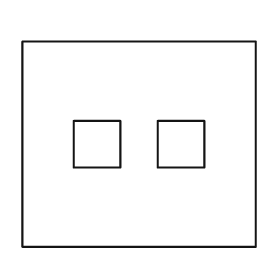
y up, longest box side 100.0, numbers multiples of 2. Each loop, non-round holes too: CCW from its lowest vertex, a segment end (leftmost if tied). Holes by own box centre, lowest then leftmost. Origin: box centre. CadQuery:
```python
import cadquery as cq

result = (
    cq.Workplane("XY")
    .moveTo(-50.0, -44.0)
    .lineTo(50.0, -44.0)
    .lineTo(50.0, 44.0)
    .lineTo(-50.0, 44.0)
    .close()
    .moveTo(-28.0, -10.0)
    .lineTo(-8.0, -10.0)
    .lineTo(-8.0, 10.0)
    .lineTo(-28.0, 10.0)
    .close()
    .moveTo(8.0, -10.0)
    .lineTo(28.0, -10.0)
    .lineTo(28.0, 10.0)
    .lineTo(8.0, 10.0)
    .close()
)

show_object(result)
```